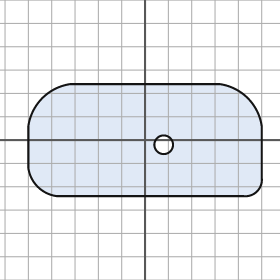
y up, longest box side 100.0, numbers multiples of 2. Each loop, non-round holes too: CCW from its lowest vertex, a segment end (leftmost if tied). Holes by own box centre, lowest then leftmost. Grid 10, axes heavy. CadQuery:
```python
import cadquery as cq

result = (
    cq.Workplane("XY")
    .moveTo(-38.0, -24.0)
    .lineTo(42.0, -24.0)
    .threePointArc((48.0, -22.0), (50.0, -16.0))
    .lineTo(50.0, 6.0)
    .threePointArc((44.0, 18.0), (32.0, 24.0))
    .lineTo(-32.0, 24.0)
    .threePointArc((-44.0, 18.0), (-50.0, 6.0))
    .lineTo(-50.0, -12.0)
    .threePointArc((-46.0, -20.0), (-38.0, -24.0))
    .close()
    .moveTo(8.0, -2.0)
    .circle(4.0)
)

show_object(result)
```